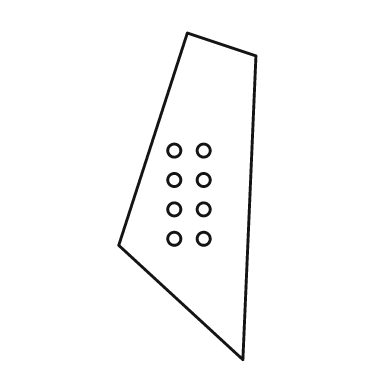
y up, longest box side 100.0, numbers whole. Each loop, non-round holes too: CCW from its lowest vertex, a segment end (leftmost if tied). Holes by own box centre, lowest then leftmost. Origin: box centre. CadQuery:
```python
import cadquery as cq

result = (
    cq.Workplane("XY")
    .moveTo(17.0, -50.0)
    .lineTo(21.0, 43.0)
    .lineTo(0.0, 50.0)
    .lineTo(-21.0, -15.0)
    .close()
    .moveTo(-4.0, -13.0)
    .circle(2.0)
    .moveTo(5.0, -13.0)
    .circle(2.0)
    .moveTo(-4.0, -4.0)
    .circle(2.0)
    .moveTo(5.0, -4.0)
    .circle(2.0)
    .moveTo(-4.0, 5.0)
    .circle(2.0)
    .moveTo(5.0, 5.0)
    .circle(2.0)
    .moveTo(-4.0, 14.0)
    .circle(2.0)
    .moveTo(5.0, 14.0)
    .circle(2.0)
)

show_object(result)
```